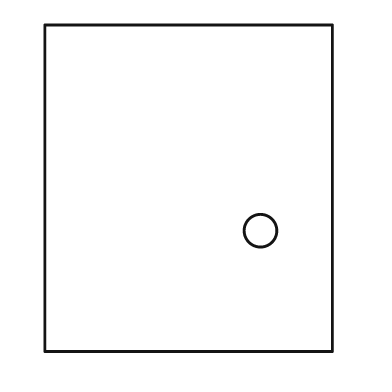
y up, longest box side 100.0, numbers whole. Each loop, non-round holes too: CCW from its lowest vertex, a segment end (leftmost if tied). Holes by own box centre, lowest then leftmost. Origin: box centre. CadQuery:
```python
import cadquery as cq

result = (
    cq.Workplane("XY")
    .moveTo(-44.0, -50.0)
    .lineTo(44.0, -50.0)
    .lineTo(44.0, 50.0)
    .lineTo(-44.0, 50.0)
    .close()
    .moveTo(22.0, -13.0)
    .circle(5.0)
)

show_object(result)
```